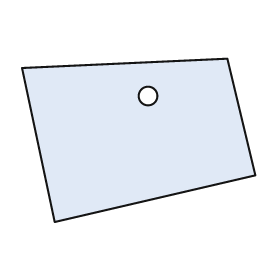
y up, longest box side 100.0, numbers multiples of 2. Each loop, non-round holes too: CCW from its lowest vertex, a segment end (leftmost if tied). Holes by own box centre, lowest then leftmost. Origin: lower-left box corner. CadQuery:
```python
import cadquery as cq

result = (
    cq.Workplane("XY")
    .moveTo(14.0, 0.0)
    .lineTo(100.0, 20.0)
    .lineTo(88.0, 70.0)
    .lineTo(0.0, 66.0)
    .close()
    .moveTo(54.0, 54.0)
    .circle(4.0)
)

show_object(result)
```